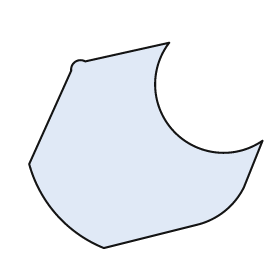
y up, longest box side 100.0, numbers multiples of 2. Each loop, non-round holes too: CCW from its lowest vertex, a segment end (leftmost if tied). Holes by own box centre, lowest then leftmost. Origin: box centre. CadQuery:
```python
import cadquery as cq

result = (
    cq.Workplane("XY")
    .moveTo(-18.0, -44.0)
    .lineTo(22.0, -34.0)
    .threePointArc((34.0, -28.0), (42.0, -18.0))
    .lineTo(50.0, 2.0)
    .threePointArc((12.0, 6.0), (10.0, 44.0))
    .lineTo(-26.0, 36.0)
    .threePointArc((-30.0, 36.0), (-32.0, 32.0))
    .lineTo(-50.0, -8.0)
    .threePointArc((-38.0, -30.0), (-18.0, -44.0))
    .close()
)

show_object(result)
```